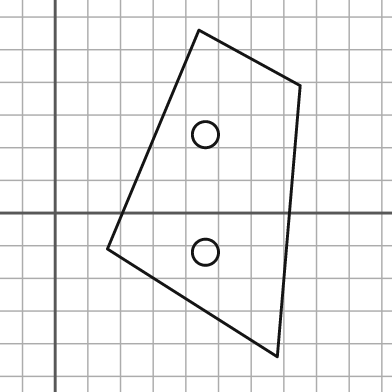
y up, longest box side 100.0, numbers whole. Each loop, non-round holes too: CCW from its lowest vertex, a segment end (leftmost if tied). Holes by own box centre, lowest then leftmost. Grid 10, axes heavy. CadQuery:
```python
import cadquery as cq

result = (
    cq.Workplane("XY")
    .moveTo(68.0, -44.0)
    .lineTo(75.0, 39.0)
    .lineTo(44.0, 56.0)
    .lineTo(16.0, -11.0)
    .close()
    .moveTo(46.0, -12.0)
    .circle(4.0)
    .moveTo(46.0, 24.0)
    .circle(4.0)
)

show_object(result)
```